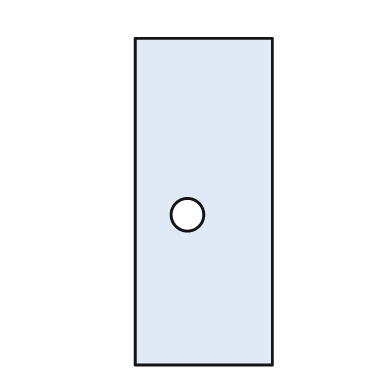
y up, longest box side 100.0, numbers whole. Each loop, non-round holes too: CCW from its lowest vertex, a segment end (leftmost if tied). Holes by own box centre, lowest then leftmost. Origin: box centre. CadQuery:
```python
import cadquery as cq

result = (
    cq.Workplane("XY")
    .moveTo(-21.0, -50.0)
    .lineTo(21.0, -50.0)
    .lineTo(21.0, 50.0)
    .lineTo(-21.0, 50.0)
    .close()
    .moveTo(-5.0, -4.0)
    .circle(5.0)
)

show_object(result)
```